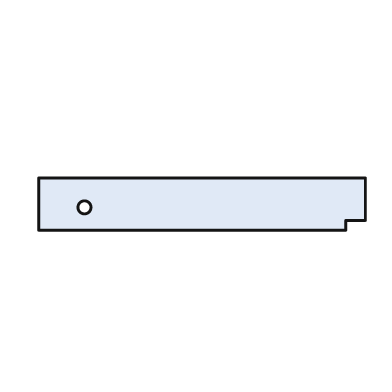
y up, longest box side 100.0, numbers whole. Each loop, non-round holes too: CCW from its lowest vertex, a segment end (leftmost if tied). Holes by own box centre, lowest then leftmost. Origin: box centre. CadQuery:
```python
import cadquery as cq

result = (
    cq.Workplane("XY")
    .moveTo(-50.0, -8.0)
    .lineTo(44.0, -8.0)
    .lineTo(44.0, -5.0)
    .lineTo(50.0, -5.0)
    .lineTo(50.0, 8.0)
    .lineTo(-50.0, 8.0)
    .close()
    .moveTo(-36.0, -1.0)
    .circle(2.0)
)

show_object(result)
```